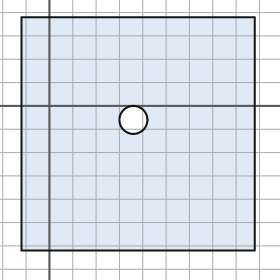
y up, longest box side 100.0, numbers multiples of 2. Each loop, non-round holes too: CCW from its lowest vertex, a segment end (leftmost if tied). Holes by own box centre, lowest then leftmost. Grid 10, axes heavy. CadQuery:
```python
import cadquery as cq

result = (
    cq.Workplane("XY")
    .moveTo(-12.0, -62.0)
    .lineTo(88.0, -62.0)
    .lineTo(88.0, 38.0)
    .lineTo(-12.0, 38.0)
    .close()
    .moveTo(36.0, -6.0)
    .circle(6.0)
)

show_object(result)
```